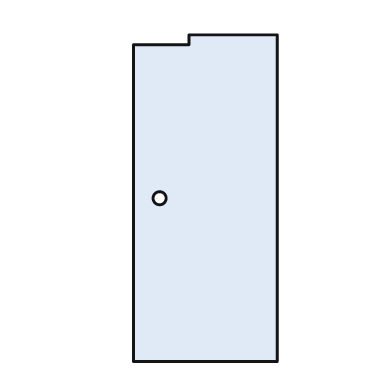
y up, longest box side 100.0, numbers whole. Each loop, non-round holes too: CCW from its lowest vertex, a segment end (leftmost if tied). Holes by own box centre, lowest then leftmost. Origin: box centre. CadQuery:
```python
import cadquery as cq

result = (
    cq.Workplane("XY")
    .moveTo(-22.0, -50.0)
    .lineTo(22.0, -50.0)
    .lineTo(22.0, 50.0)
    .lineTo(-5.0, 50.0)
    .lineTo(-5.0, 47.0)
    .lineTo(-22.0, 47.0)
    .close()
    .moveTo(-14.0, 0.0)
    .circle(2.0)
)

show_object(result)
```